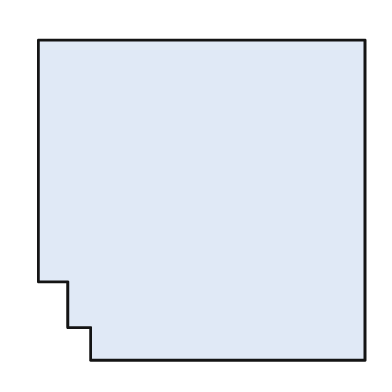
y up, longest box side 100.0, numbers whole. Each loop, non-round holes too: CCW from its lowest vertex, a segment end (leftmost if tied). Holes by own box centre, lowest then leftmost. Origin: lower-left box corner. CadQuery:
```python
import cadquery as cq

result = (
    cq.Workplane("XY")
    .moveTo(16.0, 0.0)
    .lineTo(100.0, 0.0)
    .lineTo(100.0, 98.0)
    .lineTo(0.0, 98.0)
    .lineTo(0.0, 24.0)
    .lineTo(9.0, 24.0)
    .lineTo(9.0, 10.0)
    .lineTo(16.0, 10.0)
    .close()
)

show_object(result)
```